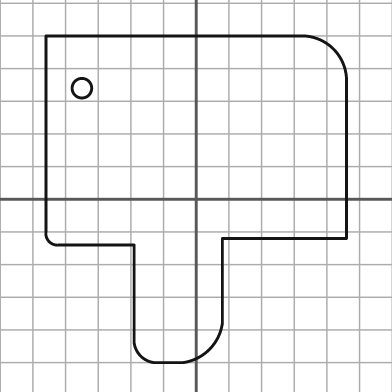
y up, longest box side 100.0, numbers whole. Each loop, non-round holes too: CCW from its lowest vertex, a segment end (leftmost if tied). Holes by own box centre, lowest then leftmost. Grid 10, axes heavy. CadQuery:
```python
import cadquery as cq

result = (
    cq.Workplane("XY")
    .moveTo(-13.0, -50.0)
    .lineTo(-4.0, -50.0)
    .threePointArc((4.0, -46.0), (8.0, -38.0))
    .lineTo(8.0, -12.0)
    .lineTo(46.0, -12.0)
    .lineTo(46.0, 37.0)
    .threePointArc((42.0, 46.0), (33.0, 50.0))
    .lineTo(-46.0, 50.0)
    .lineTo(-46.0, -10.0)
    .threePointArc((-45.0, -13.0), (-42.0, -14.0))
    .lineTo(-19.0, -14.0)
    .lineTo(-19.0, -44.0)
    .threePointArc((-17.0, -48.0), (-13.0, -50.0))
    .close()
    .moveTo(-35.0, 34.0)
    .circle(3.0)
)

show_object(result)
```